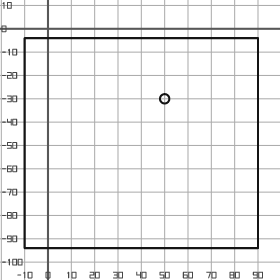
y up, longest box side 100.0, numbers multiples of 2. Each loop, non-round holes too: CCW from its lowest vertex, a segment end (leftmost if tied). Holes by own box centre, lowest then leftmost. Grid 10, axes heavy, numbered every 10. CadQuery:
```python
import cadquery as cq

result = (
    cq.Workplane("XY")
    .moveTo(-10.0, -94.0)
    .lineTo(90.0, -94.0)
    .lineTo(90.0, -4.0)
    .lineTo(-10.0, -4.0)
    .close()
    .moveTo(50.0, -30.0)
    .circle(2.0)
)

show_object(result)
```